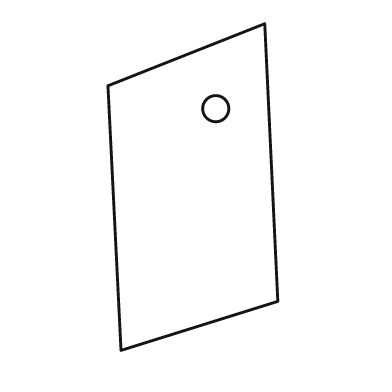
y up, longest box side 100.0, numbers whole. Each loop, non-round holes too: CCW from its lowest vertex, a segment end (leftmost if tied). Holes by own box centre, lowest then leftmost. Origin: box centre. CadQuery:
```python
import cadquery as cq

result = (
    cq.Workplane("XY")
    .moveTo(-22.0, -50.0)
    .lineTo(26.0, -35.0)
    .lineTo(22.0, 50.0)
    .lineTo(-26.0, 31.0)
    .close()
    .moveTo(7.0, 24.0)
    .circle(4.0)
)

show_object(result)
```